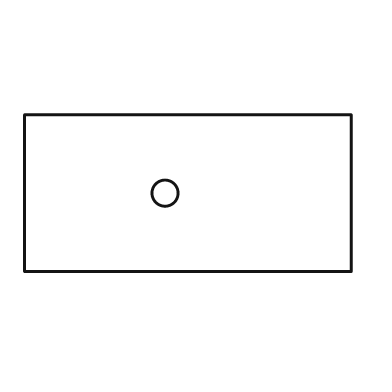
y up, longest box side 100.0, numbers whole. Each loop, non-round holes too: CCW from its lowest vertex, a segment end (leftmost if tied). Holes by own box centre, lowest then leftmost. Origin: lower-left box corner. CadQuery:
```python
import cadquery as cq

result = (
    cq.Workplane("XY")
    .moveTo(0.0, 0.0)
    .lineTo(100.0, 0.0)
    .lineTo(100.0, 48.0)
    .lineTo(0.0, 48.0)
    .close()
    .moveTo(43.0, 24.0)
    .circle(4.0)
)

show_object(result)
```